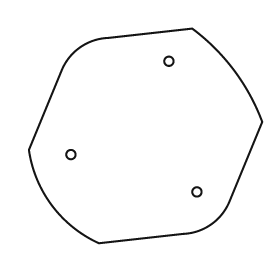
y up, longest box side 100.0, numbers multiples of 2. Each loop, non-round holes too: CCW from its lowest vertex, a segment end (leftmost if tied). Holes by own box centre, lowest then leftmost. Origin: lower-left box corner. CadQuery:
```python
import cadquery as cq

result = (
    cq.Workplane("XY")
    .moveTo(30.0, 0.0)
    .lineTo(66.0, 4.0)
    .threePointArc((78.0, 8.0), (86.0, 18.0))
    .lineTo(100.0, 52.0)
    .threePointArc((88.0, 74.0), (70.0, 92.0))
    .lineTo(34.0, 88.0)
    .threePointArc((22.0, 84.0), (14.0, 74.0))
    .lineTo(0.0, 40.0)
    .threePointArc((10.0, 16.0), (30.0, 0.0))
    .close()
    .moveTo(72.0, 22.0)
    .circle(2.0)
    .moveTo(18.0, 38.0)
    .circle(2.0)
    .moveTo(60.0, 78.0)
    .circle(2.0)
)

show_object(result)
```